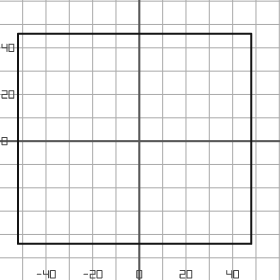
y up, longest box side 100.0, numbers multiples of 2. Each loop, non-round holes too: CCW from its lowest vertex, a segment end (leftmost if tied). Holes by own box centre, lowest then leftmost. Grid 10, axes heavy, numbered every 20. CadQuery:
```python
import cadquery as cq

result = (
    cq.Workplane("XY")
    .moveTo(-52.0, -44.0)
    .lineTo(48.0, -44.0)
    .lineTo(48.0, 46.0)
    .lineTo(-52.0, 46.0)
    .close()
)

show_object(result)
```